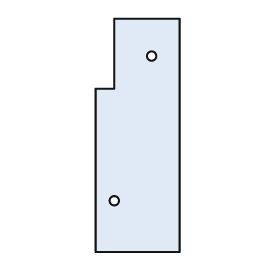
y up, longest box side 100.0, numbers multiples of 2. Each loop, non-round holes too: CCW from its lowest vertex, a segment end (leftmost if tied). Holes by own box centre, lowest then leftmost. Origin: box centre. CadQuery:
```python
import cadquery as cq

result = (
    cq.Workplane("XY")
    .moveTo(-18.0, -50.0)
    .lineTo(18.0, -50.0)
    .lineTo(18.0, 50.0)
    .lineTo(-10.0, 50.0)
    .lineTo(-10.0, 20.0)
    .lineTo(-18.0, 20.0)
    .close()
    .moveTo(-10.0, -28.0)
    .circle(2.0)
    .moveTo(6.0, 34.0)
    .circle(2.0)
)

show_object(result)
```